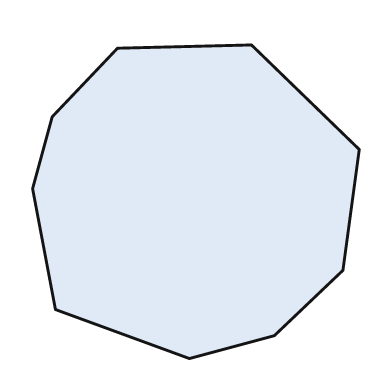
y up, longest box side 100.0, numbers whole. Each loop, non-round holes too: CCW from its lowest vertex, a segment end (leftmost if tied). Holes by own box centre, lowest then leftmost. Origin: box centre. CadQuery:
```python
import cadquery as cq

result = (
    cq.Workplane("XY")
    .moveTo(-2.0, -48.0)
    .lineTo(24.0, -41.0)
    .lineTo(45.0, -21.0)
    .lineTo(50.0, 16.0)
    .lineTo(17.0, 48.0)
    .lineTo(-24.0, 47.0)
    .lineTo(-44.0, 26.0)
    .lineTo(-50.0, 4.0)
    .lineTo(-43.0, -33.0)
    .close()
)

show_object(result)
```